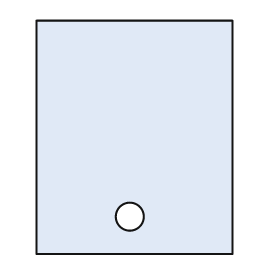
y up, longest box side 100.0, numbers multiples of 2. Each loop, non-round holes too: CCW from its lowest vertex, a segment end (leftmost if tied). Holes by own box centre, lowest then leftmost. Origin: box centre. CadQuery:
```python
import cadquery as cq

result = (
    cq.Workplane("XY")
    .moveTo(-42.0, -50.0)
    .lineTo(42.0, -50.0)
    .lineTo(42.0, 50.0)
    .lineTo(-42.0, 50.0)
    .close()
    .moveTo(-2.0, -34.0)
    .circle(6.0)
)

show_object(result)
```